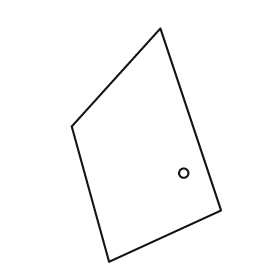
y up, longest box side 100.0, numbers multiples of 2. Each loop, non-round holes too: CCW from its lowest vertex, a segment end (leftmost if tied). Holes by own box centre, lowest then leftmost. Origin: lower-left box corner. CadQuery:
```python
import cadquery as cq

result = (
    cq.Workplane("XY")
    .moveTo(16.0, 0.0)
    .lineTo(64.0, 22.0)
    .lineTo(38.0, 100.0)
    .lineTo(0.0, 58.0)
    .close()
    .moveTo(48.0, 38.0)
    .circle(2.0)
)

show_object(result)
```